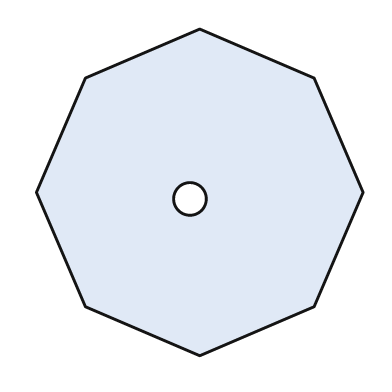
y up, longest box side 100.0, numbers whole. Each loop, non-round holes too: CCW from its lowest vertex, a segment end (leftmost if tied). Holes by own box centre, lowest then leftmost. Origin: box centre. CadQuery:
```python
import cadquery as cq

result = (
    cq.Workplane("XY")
    .moveTo(0.0, -50.0)
    .lineTo(35.0, -35.0)
    .lineTo(50.0, 0.0)
    .lineTo(35.0, 35.0)
    .lineTo(0.0, 50.0)
    .lineTo(-35.0, 35.0)
    .lineTo(-50.0, 0.0)
    .lineTo(-35.0, -35.0)
    .close()
    .moveTo(-3.0, -2.0)
    .circle(5.0)
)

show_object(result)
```